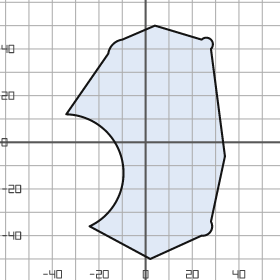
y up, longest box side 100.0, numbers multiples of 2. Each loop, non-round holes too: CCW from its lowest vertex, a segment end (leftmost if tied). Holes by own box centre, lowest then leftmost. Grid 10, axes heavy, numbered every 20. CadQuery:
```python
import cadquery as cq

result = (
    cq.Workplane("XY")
    .moveTo(2.0, -50.0)
    .lineTo(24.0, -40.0)
    .threePointArc((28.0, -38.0), (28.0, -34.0))
    .lineTo(34.0, -6.0)
    .lineTo(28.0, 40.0)
    .threePointArc((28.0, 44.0), (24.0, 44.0))
    .lineTo(4.0, 50.0)
    .lineTo(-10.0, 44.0)
    .threePointArc((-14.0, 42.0), (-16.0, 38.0))
    .lineTo(-34.0, 12.0)
    .threePointArc((-10.0, -8.0), (-24.0, -36.0))
    .close()
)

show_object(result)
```